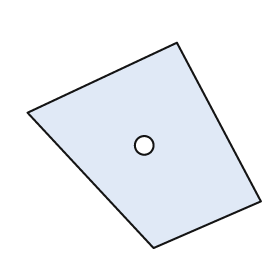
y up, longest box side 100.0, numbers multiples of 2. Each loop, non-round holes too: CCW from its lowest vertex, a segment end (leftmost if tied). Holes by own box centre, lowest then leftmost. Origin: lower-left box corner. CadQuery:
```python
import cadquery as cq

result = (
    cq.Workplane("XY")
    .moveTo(54.0, 0.0)
    .lineTo(100.0, 20.0)
    .lineTo(64.0, 88.0)
    .lineTo(0.0, 58.0)
    .close()
    .moveTo(50.0, 44.0)
    .circle(4.0)
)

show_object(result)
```